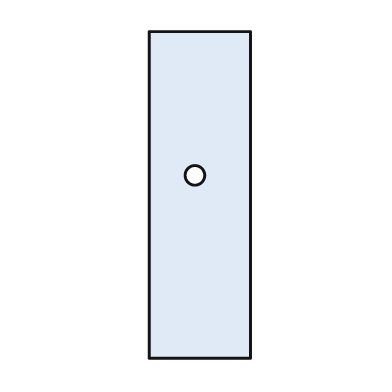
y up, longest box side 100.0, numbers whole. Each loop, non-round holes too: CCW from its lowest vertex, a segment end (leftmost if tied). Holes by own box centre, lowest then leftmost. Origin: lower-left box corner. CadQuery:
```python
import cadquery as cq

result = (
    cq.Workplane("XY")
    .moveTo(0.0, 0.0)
    .lineTo(31.0, 0.0)
    .lineTo(31.0, 100.0)
    .lineTo(0.0, 100.0)
    .close()
    .moveTo(14.0, 56.0)
    .circle(3.0)
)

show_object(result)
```